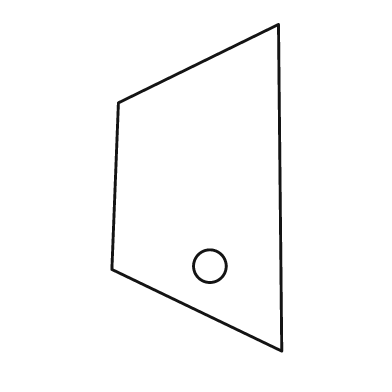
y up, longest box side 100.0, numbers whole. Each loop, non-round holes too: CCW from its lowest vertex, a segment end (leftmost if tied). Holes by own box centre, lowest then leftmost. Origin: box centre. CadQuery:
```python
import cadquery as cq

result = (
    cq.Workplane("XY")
    .moveTo(26.0, -50.0)
    .lineTo(25.0, 50.0)
    .lineTo(-24.0, 26.0)
    .lineTo(-26.0, -25.0)
    .close()
    .moveTo(4.0, -24.0)
    .circle(5.0)
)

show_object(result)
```